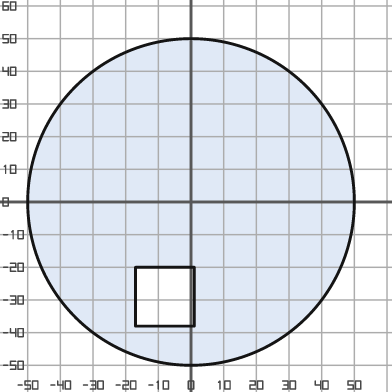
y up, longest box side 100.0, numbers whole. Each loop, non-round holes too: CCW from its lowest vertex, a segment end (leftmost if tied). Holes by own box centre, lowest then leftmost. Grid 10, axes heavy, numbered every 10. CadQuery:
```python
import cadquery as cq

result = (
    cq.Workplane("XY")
    .moveTo(0.0, 0.0)
    .circle(50.0)
    .moveTo(-17.0, -38.0)
    .lineTo(1.0, -38.0)
    .lineTo(1.0, -20.0)
    .lineTo(-17.0, -20.0)
    .close()
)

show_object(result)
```